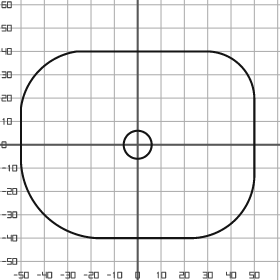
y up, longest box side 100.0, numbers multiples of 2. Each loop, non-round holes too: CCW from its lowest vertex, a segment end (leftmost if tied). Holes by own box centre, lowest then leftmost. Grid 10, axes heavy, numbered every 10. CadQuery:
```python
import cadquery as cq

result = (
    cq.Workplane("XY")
    .moveTo(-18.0, -40.0)
    .lineTo(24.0, -40.0)
    .threePointArc((42.0, -32.0), (50.0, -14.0))
    .lineTo(50.0, 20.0)
    .threePointArc((44.0, 34.0), (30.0, 40.0))
    .lineTo(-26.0, 40.0)
    .threePointArc((-42.0, 32.0), (-50.0, 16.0))
    .lineTo(-50.0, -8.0)
    .threePointArc((-40.0, -30.0), (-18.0, -40.0))
    .close()
    .moveTo(0.0, 0.0)
    .circle(6.0)
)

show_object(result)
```